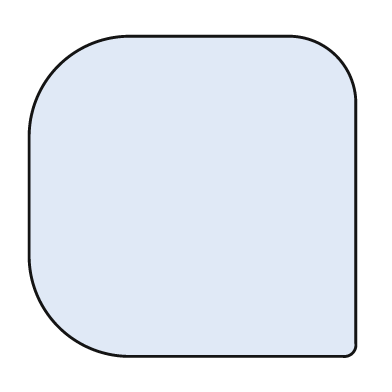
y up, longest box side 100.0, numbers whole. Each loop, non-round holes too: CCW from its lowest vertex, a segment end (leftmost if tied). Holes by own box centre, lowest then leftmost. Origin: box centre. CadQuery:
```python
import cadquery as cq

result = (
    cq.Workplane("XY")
    .moveTo(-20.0, -49.0)
    .lineTo(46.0, -49.0)
    .threePointArc((49.0, -48.0), (50.0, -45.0))
    .lineTo(50.0, 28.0)
    .threePointArc((44.0, 43.0), (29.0, 49.0))
    .lineTo(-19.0, 49.0)
    .threePointArc((-41.0, 40.0), (-50.0, 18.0))
    .lineTo(-50.0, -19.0)
    .threePointArc((-41.0, -40.0), (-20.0, -49.0))
    .close()
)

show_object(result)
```